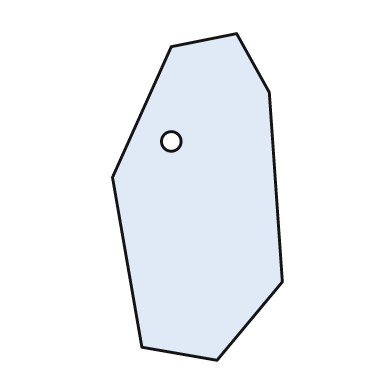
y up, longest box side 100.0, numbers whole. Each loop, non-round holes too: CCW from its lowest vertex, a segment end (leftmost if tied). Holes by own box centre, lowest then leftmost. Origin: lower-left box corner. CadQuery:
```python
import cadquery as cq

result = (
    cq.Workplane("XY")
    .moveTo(32.0, 0.0)
    .lineTo(52.0, 24.0)
    .lineTo(48.0, 82.0)
    .lineTo(38.0, 100.0)
    .lineTo(18.0, 96.0)
    .lineTo(0.0, 56.0)
    .lineTo(9.0, 4.0)
    .close()
    .moveTo(18.0, 67.0)
    .circle(3.0)
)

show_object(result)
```